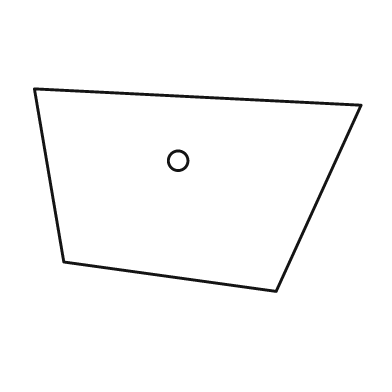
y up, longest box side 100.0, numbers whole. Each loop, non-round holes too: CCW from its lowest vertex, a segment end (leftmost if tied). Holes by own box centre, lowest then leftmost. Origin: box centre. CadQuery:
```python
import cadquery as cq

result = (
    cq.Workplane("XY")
    .moveTo(24.0, -31.0)
    .lineTo(50.0, 26.0)
    .lineTo(-50.0, 31.0)
    .lineTo(-41.0, -22.0)
    .close()
    .moveTo(-6.0, 9.0)
    .circle(3.0)
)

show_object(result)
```